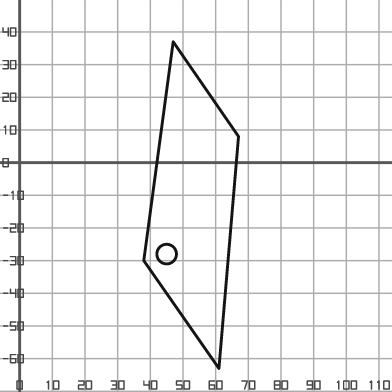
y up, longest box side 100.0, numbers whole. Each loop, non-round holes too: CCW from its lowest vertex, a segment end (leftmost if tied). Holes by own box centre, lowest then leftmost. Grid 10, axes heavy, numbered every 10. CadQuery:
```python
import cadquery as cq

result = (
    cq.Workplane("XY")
    .moveTo(61.0, -63.0)
    .lineTo(67.0, 8.0)
    .lineTo(47.0, 37.0)
    .lineTo(38.0, -30.0)
    .close()
    .moveTo(45.0, -28.0)
    .circle(3.0)
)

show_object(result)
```